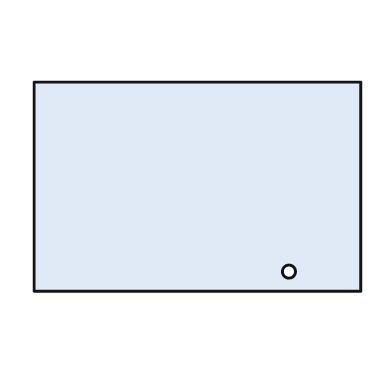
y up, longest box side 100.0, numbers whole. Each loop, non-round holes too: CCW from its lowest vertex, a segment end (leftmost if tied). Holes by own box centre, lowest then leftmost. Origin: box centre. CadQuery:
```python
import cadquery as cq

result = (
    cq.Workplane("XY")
    .moveTo(-50.0, -32.0)
    .lineTo(50.0, -32.0)
    .lineTo(50.0, 32.0)
    .lineTo(-50.0, 32.0)
    .close()
    .moveTo(28.0, -26.0)
    .circle(2.0)
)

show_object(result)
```